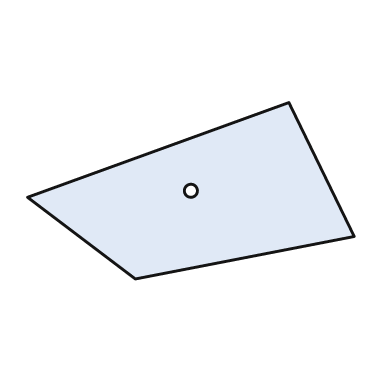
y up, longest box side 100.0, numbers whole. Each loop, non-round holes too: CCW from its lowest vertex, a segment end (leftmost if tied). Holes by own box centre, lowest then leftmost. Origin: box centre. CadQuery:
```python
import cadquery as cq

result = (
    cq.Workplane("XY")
    .moveTo(-17.0, -27.0)
    .lineTo(50.0, -14.0)
    .lineTo(30.0, 27.0)
    .lineTo(-50.0, -2.0)
    .close()
    .moveTo(0.0, 0.0)
    .circle(2.0)
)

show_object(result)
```